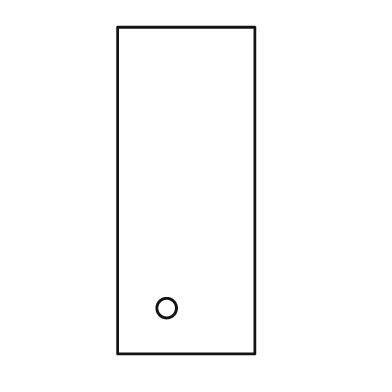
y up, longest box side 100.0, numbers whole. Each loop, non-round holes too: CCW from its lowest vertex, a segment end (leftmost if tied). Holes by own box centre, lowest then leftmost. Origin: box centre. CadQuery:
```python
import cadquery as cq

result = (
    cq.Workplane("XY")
    .moveTo(-21.0, -50.0)
    .lineTo(21.0, -50.0)
    .lineTo(21.0, 50.0)
    .lineTo(-21.0, 50.0)
    .close()
    .moveTo(-6.0, -36.0)
    .circle(3.0)
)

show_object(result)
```